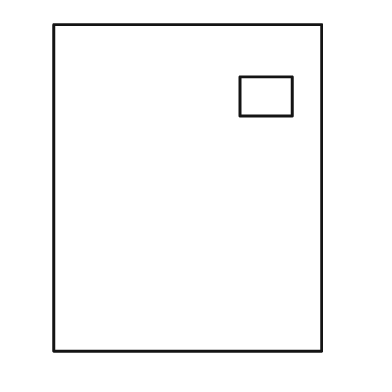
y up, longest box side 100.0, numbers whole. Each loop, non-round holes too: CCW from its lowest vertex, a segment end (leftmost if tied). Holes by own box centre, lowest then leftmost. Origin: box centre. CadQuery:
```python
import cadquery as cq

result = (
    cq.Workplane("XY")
    .moveTo(-41.0, -50.0)
    .lineTo(41.0, -50.0)
    .lineTo(41.0, 50.0)
    .lineTo(-41.0, 50.0)
    .close()
    .moveTo(16.0, 22.0)
    .lineTo(32.0, 22.0)
    .lineTo(32.0, 34.0)
    .lineTo(16.0, 34.0)
    .close()
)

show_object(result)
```